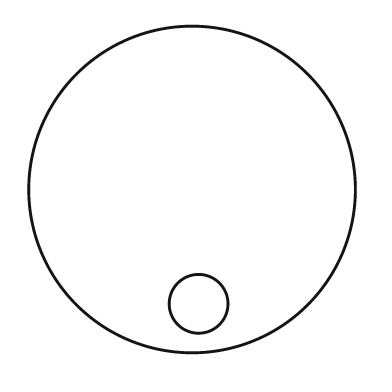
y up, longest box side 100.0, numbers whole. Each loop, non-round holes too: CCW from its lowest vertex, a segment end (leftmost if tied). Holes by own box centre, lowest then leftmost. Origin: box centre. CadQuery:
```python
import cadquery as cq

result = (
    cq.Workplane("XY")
    .moveTo(0.0, 0.0)
    .circle(50.0)
    .moveTo(2.0, -35.0)
    .circle(9.0)
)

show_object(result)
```